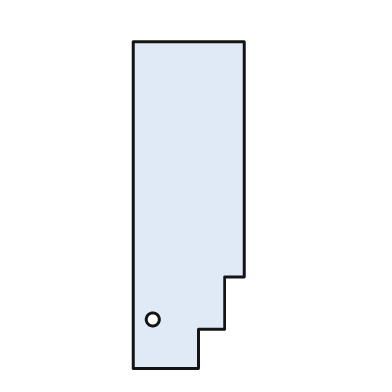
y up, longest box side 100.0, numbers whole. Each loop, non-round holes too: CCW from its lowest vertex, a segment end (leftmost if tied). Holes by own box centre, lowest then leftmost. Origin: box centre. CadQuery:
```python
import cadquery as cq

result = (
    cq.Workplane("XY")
    .moveTo(-17.0, -50.0)
    .lineTo(3.0, -50.0)
    .lineTo(3.0, -38.0)
    .lineTo(11.0, -38.0)
    .lineTo(11.0, -22.0)
    .lineTo(17.0, -22.0)
    .lineTo(17.0, 50.0)
    .lineTo(-17.0, 50.0)
    .close()
    .moveTo(-11.0, -35.0)
    .circle(2.0)
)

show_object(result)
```